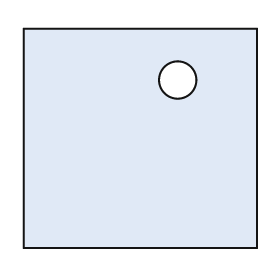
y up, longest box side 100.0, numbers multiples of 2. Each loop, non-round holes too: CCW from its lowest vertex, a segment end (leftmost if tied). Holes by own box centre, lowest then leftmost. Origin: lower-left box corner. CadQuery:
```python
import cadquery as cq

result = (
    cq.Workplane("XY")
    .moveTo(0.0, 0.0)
    .lineTo(100.0, 0.0)
    .lineTo(100.0, 94.0)
    .lineTo(0.0, 94.0)
    .close()
    .moveTo(66.0, 72.0)
    .circle(8.0)
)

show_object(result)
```